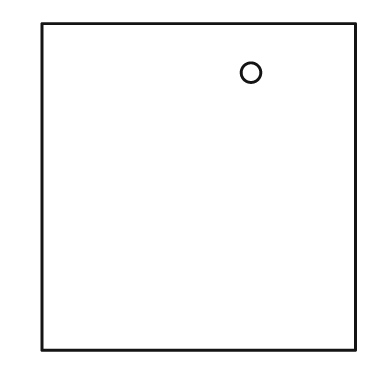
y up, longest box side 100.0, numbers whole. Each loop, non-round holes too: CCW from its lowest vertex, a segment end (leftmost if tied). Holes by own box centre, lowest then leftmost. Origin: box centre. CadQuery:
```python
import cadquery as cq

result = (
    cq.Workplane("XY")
    .moveTo(-48.0, -50.0)
    .lineTo(48.0, -50.0)
    .lineTo(48.0, 50.0)
    .lineTo(-48.0, 50.0)
    .close()
    .moveTo(16.0, 35.0)
    .circle(3.0)
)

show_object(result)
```